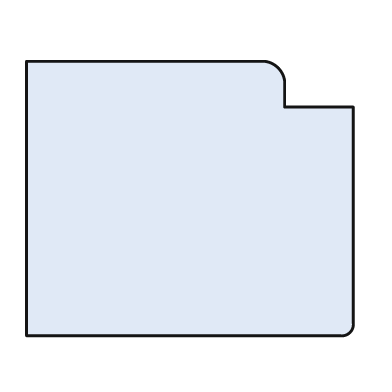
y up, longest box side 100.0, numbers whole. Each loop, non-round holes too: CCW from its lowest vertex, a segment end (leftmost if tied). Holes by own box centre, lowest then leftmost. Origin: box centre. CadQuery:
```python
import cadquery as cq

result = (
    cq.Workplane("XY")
    .moveTo(-50.0, -42.0)
    .lineTo(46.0, -42.0)
    .threePointArc((49.0, -41.0), (50.0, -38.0))
    .lineTo(50.0, 28.0)
    .lineTo(29.0, 28.0)
    .lineTo(29.0, 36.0)
    .threePointArc((27.0, 40.0), (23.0, 42.0))
    .lineTo(-50.0, 42.0)
    .close()
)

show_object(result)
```